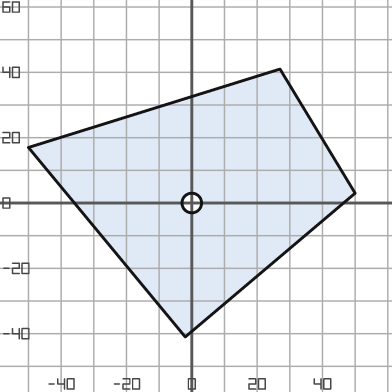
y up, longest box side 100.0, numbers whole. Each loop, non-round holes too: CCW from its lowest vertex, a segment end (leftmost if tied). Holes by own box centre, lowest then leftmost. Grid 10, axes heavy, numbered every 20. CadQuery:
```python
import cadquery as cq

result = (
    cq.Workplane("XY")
    .moveTo(-2.0, -41.0)
    .lineTo(50.0, 3.0)
    .lineTo(27.0, 41.0)
    .lineTo(-50.0, 17.0)
    .close()
    .moveTo(0.0, 0.0)
    .circle(3.0)
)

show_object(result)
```